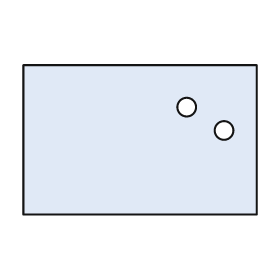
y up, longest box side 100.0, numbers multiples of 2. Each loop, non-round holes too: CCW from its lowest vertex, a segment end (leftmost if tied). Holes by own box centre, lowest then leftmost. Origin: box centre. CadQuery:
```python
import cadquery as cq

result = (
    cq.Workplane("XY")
    .moveTo(-50.0, -32.0)
    .lineTo(50.0, -32.0)
    .lineTo(50.0, 32.0)
    .lineTo(-50.0, 32.0)
    .close()
    .moveTo(36.0, 4.0)
    .circle(4.0)
    .moveTo(20.0, 14.0)
    .circle(4.0)
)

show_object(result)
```